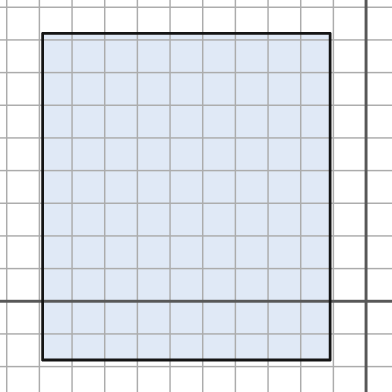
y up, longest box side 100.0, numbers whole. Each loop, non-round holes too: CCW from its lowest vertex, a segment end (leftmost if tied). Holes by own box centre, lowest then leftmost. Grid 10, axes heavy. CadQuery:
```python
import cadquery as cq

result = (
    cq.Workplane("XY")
    .moveTo(-99.0, -18.0)
    .lineTo(-11.0, -18.0)
    .lineTo(-11.0, 82.0)
    .lineTo(-99.0, 82.0)
    .close()
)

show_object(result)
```